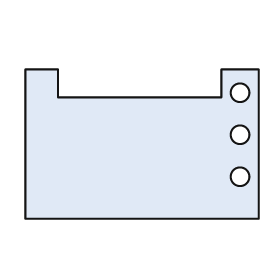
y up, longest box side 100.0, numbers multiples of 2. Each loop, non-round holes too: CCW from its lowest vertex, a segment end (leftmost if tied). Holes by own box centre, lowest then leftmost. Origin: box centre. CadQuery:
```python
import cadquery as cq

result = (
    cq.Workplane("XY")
    .moveTo(-50.0, -32.0)
    .lineTo(50.0, -32.0)
    .lineTo(50.0, 32.0)
    .lineTo(34.0, 32.0)
    .lineTo(34.0, 20.0)
    .lineTo(-36.0, 20.0)
    .lineTo(-36.0, 32.0)
    .lineTo(-50.0, 32.0)
    .close()
    .moveTo(42.0, -14.0)
    .circle(4.0)
    .moveTo(42.0, 4.0)
    .circle(4.0)
    .moveTo(42.0, 22.0)
    .circle(4.0)
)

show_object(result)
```